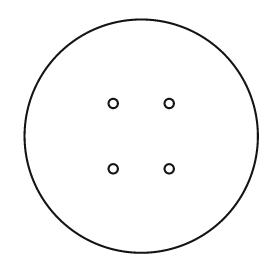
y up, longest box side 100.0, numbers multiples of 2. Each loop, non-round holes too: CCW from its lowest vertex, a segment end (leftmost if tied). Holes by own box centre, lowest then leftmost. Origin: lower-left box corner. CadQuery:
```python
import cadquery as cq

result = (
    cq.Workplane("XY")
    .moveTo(50.0, 50.0)
    .circle(50.0)
    .moveTo(38.0, 36.0)
    .circle(2.0)
    .moveTo(62.0, 36.0)
    .circle(2.0)
    .moveTo(38.0, 64.0)
    .circle(2.0)
    .moveTo(62.0, 64.0)
    .circle(2.0)
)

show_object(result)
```